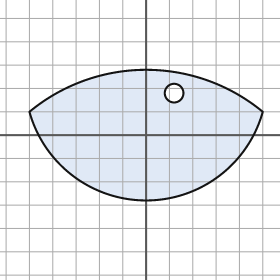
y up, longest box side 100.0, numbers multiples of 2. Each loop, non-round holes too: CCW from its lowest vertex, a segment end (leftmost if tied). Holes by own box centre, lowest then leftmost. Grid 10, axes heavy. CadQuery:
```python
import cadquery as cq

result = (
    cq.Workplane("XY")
    .moveTo(-50.0, 10.0)
    .threePointArc((0.0, -28.0), (50.0, 10.0))
    .threePointArc((0.0, 28.0), (-50.0, 10.0))
    .close()
    .moveTo(12.0, 18.0)
    .circle(4.0)
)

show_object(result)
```